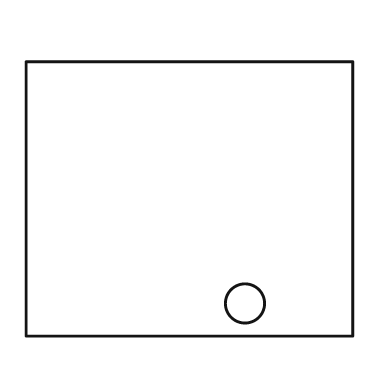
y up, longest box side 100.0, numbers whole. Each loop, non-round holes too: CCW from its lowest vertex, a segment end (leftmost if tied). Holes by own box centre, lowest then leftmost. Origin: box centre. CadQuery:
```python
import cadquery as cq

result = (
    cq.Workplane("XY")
    .moveTo(-50.0, -42.0)
    .lineTo(50.0, -42.0)
    .lineTo(50.0, 42.0)
    .lineTo(-50.0, 42.0)
    .close()
    .moveTo(17.0, -32.0)
    .circle(6.0)
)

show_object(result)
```